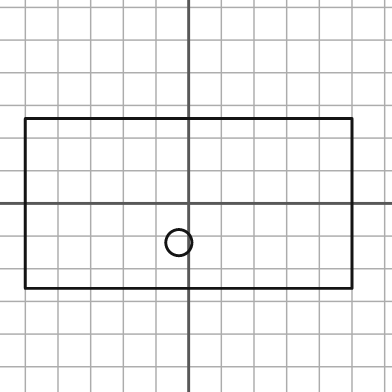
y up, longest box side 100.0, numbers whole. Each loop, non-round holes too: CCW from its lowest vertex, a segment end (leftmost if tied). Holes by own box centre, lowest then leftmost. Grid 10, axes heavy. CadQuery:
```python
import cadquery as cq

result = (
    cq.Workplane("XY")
    .moveTo(-50.0, -26.0)
    .lineTo(50.0, -26.0)
    .lineTo(50.0, 26.0)
    .lineTo(-50.0, 26.0)
    .close()
    .moveTo(-3.0, -12.0)
    .circle(4.0)
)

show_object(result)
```